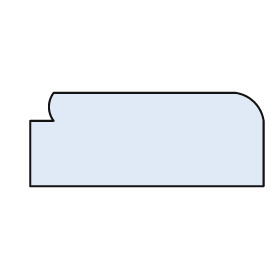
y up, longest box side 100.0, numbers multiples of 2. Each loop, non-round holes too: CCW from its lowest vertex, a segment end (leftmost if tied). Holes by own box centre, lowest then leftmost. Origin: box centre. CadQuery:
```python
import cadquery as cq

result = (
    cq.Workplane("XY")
    .moveTo(-50.0, -20.0)
    .lineTo(50.0, -20.0)
    .lineTo(50.0, 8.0)
    .threePointArc((46.0, 16.0), (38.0, 20.0))
    .lineTo(-40.0, 20.0)
    .threePointArc((-42.0, 14.0), (-40.0, 8.0))
    .lineTo(-50.0, 8.0)
    .close()
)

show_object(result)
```